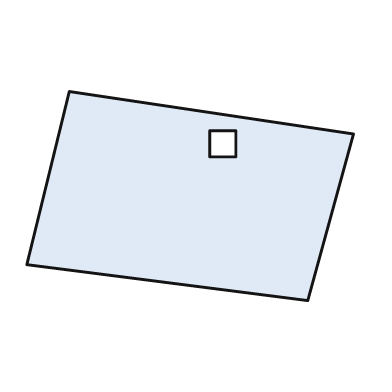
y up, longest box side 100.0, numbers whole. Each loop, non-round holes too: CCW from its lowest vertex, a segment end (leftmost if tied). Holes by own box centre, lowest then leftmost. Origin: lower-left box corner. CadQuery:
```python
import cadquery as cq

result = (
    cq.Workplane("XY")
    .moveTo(86.0, 0.0)
    .lineTo(100.0, 51.0)
    .lineTo(13.0, 64.0)
    .lineTo(0.0, 11.0)
    .close()
    .moveTo(56.0, 44.0)
    .lineTo(64.0, 44.0)
    .lineTo(64.0, 52.0)
    .lineTo(56.0, 52.0)
    .close()
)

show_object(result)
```